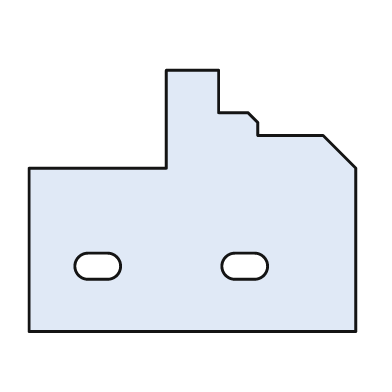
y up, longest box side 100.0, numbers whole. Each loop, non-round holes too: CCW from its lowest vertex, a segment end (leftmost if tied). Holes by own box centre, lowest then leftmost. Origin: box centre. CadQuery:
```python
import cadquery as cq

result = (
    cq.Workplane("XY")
    .moveTo(-50.0, -40.0)
    .lineTo(50.0, -40.0)
    .lineTo(50.0, 10.0)
    .lineTo(40.0, 20.0)
    .lineTo(20.0, 20.0)
    .lineTo(20.0, 24.0)
    .lineTo(17.0, 27.0)
    .lineTo(8.0, 27.0)
    .lineTo(8.0, 40.0)
    .lineTo(-8.0, 40.0)
    .lineTo(-8.0, 10.0)
    .lineTo(-50.0, 10.0)
    .close()
    .moveTo(-32.0, -24.0)
    .lineTo(-26.0, -24.0)
    .threePointArc((-22.0, -20.0), (-26.0, -16.0))
    .lineTo(-32.0, -16.0)
    .threePointArc((-36.0, -20.0), (-32.0, -24.0))
    .close()
    .moveTo(13.0, -24.0)
    .lineTo(19.0, -24.0)
    .threePointArc((23.0, -20.0), (19.0, -16.0))
    .lineTo(13.0, -16.0)
    .threePointArc((9.0, -20.0), (13.0, -24.0))
    .close()
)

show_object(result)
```